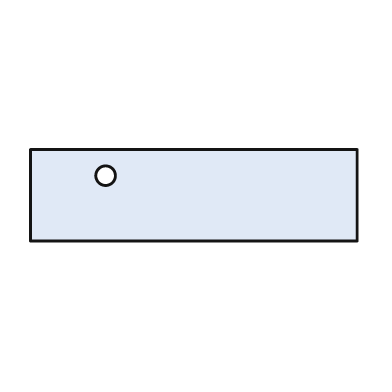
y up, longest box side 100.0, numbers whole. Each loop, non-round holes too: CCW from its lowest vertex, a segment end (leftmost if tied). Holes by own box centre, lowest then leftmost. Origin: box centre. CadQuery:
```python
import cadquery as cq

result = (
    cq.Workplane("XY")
    .moveTo(-50.0, -14.0)
    .lineTo(50.0, -14.0)
    .lineTo(50.0, 14.0)
    .lineTo(-50.0, 14.0)
    .close()
    .moveTo(-27.0, 6.0)
    .circle(3.0)
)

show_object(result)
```